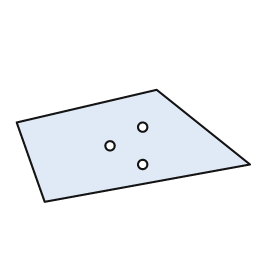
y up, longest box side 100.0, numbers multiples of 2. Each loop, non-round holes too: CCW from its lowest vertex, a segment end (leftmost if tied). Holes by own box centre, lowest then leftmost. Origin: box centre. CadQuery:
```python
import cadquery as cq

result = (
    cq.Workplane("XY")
    .moveTo(-38.0, -24.0)
    .lineTo(50.0, -8.0)
    .lineTo(10.0, 24.0)
    .lineTo(-50.0, 10.0)
    .close()
    .moveTo(4.0, -8.0)
    .circle(2.0)
    .moveTo(-10.0, 0.0)
    .circle(2.0)
    .moveTo(4.0, 8.0)
    .circle(2.0)
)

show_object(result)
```